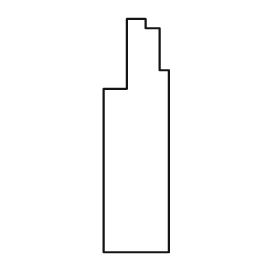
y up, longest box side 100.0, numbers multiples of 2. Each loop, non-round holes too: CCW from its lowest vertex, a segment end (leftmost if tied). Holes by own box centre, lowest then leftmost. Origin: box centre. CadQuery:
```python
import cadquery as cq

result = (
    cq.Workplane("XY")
    .moveTo(-14.0, -50.0)
    .lineTo(14.0, -50.0)
    .lineTo(14.0, 28.0)
    .lineTo(10.0, 28.0)
    .lineTo(10.0, 46.0)
    .lineTo(4.0, 46.0)
    .lineTo(4.0, 50.0)
    .lineTo(-4.0, 50.0)
    .lineTo(-4.0, 20.0)
    .lineTo(-14.0, 20.0)
    .close()
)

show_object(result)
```